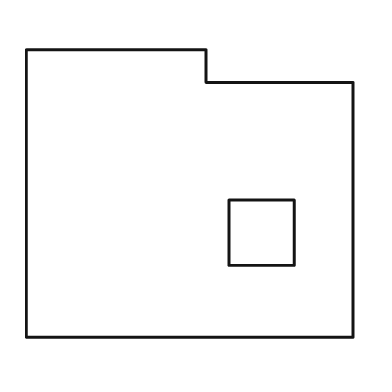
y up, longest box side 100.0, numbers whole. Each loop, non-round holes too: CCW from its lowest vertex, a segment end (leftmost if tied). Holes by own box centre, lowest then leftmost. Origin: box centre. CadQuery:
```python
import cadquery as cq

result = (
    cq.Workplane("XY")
    .moveTo(-50.0, -44.0)
    .lineTo(50.0, -44.0)
    .lineTo(50.0, 34.0)
    .lineTo(5.0, 34.0)
    .lineTo(5.0, 44.0)
    .lineTo(-50.0, 44.0)
    .close()
    .moveTo(12.0, -22.0)
    .lineTo(32.0, -22.0)
    .lineTo(32.0, -2.0)
    .lineTo(12.0, -2.0)
    .close()
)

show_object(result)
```